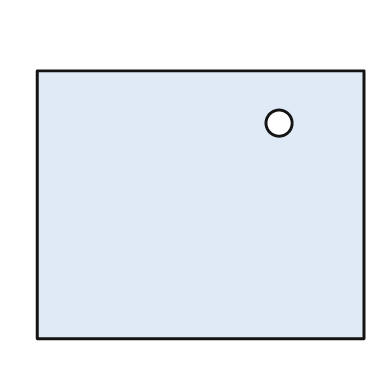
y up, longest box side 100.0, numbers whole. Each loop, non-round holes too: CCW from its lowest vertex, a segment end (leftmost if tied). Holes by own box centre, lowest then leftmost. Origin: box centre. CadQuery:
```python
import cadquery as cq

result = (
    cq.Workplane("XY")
    .moveTo(-50.0, -41.0)
    .lineTo(50.0, -41.0)
    .lineTo(50.0, 41.0)
    .lineTo(-50.0, 41.0)
    .close()
    .moveTo(24.0, 25.0)
    .circle(4.0)
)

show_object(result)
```